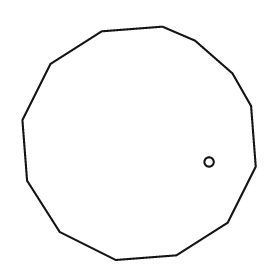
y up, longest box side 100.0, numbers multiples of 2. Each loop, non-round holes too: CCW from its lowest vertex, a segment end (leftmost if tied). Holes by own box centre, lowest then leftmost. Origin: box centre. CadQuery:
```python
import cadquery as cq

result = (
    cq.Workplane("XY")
    .moveTo(-10.0, -50.0)
    .lineTo(16.0, -48.0)
    .lineTo(38.0, -34.0)
    .lineTo(50.0, -10.0)
    .lineTo(48.0, 16.0)
    .lineTo(40.0, 30.0)
    .lineTo(24.0, 44.0)
    .lineTo(10.0, 50.0)
    .lineTo(-16.0, 48.0)
    .lineTo(-38.0, 34.0)
    .lineTo(-50.0, 10.0)
    .lineTo(-48.0, -16.0)
    .lineTo(-34.0, -38.0)
    .close()
    .moveTo(30.0, -8.0)
    .circle(2.0)
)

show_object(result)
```